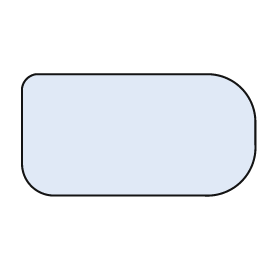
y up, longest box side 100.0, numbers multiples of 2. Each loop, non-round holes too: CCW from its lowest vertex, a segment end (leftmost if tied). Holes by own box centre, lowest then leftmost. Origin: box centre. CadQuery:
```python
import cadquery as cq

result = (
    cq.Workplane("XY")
    .moveTo(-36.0, -26.0)
    .lineTo(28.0, -26.0)
    .threePointArc((44.0, -20.0), (50.0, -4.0))
    .lineTo(50.0, 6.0)
    .threePointArc((44.0, 20.0), (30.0, 26.0))
    .lineTo(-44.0, 26.0)
    .threePointArc((-48.0, 24.0), (-50.0, 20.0))
    .lineTo(-50.0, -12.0)
    .threePointArc((-46.0, -22.0), (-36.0, -26.0))
    .close()
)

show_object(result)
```